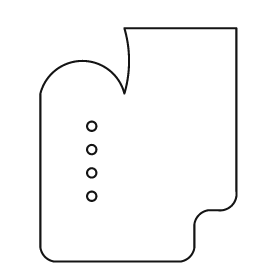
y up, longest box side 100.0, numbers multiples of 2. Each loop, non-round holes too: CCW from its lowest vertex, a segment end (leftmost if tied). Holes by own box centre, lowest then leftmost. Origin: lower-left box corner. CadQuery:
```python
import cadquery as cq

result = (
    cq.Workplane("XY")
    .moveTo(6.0, 0.0)
    .lineTo(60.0, 0.0)
    .threePointArc((64.0, 2.0), (66.0, 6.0))
    .lineTo(66.0, 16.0)
    .threePointArc((68.0, 20.0), (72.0, 22.0))
    .lineTo(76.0, 22.0)
    .threePointArc((82.0, 24.0), (84.0, 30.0))
    .lineTo(84.0, 100.0)
    .lineTo(36.0, 100.0)
    .threePointArc((38.0, 86.0), (36.0, 72.0))
    .threePointArc((18.0, 86.0), (0.0, 72.0))
    .lineTo(0.0, 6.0)
    .threePointArc((2.0, 2.0), (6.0, 0.0))
    .close()
    .moveTo(22.0, 28.0)
    .circle(2.0)
    .moveTo(22.0, 38.0)
    .circle(2.0)
    .moveTo(22.0, 48.0)
    .circle(2.0)
    .moveTo(22.0, 58.0)
    .circle(2.0)
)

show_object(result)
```